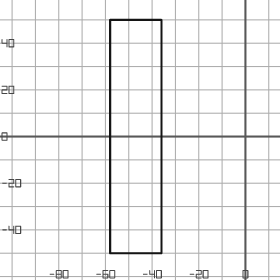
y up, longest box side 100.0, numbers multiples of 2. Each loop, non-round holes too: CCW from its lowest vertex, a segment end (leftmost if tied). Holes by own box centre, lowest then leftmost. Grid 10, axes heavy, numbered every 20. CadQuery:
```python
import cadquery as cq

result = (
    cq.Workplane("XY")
    .moveTo(-58.0, -50.0)
    .lineTo(-36.0, -50.0)
    .lineTo(-36.0, 50.0)
    .lineTo(-58.0, 50.0)
    .close()
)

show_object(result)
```